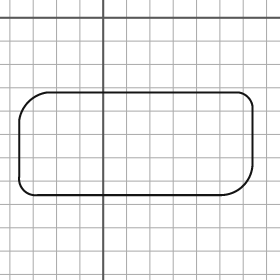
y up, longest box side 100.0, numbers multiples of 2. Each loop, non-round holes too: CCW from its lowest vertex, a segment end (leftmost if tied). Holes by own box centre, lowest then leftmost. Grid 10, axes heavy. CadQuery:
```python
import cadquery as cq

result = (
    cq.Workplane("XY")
    .moveTo(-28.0, -76.0)
    .lineTo(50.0, -76.0)
    .threePointArc((60.0, -72.0), (64.0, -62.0))
    .lineTo(64.0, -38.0)
    .threePointArc((62.0, -34.0), (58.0, -32.0))
    .lineTo(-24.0, -32.0)
    .threePointArc((-32.0, -36.0), (-36.0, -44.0))
    .lineTo(-36.0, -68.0)
    .threePointArc((-34.0, -74.0), (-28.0, -76.0))
    .close()
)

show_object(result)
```